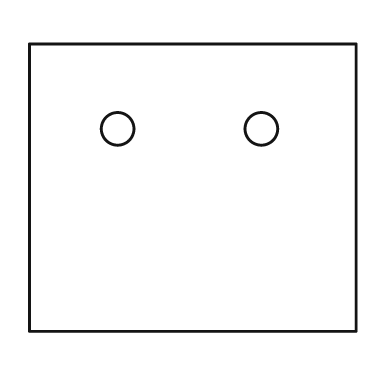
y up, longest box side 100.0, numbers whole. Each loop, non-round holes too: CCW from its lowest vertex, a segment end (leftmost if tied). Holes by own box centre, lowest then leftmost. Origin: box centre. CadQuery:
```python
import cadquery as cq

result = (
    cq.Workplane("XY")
    .moveTo(-50.0, -44.0)
    .lineTo(50.0, -44.0)
    .lineTo(50.0, 44.0)
    .lineTo(-50.0, 44.0)
    .close()
    .moveTo(-23.0, 18.0)
    .circle(5.0)
    .moveTo(21.0, 18.0)
    .circle(5.0)
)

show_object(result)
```